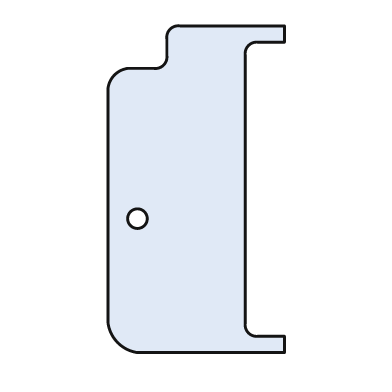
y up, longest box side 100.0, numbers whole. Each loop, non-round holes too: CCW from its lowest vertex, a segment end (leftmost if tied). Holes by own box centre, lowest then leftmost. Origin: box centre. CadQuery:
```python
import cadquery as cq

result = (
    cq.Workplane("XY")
    .moveTo(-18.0, -50.0)
    .lineTo(27.0, -50.0)
    .lineTo(27.0, -45.0)
    .lineTo(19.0, -45.0)
    .threePointArc((16.0, -44.0), (15.0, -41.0))
    .lineTo(15.0, 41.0)
    .threePointArc((16.0, 44.0), (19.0, 45.0))
    .lineTo(27.0, 45.0)
    .lineTo(27.0, 50.0)
    .lineTo(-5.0, 50.0)
    .threePointArc((-8.0, 49.0), (-9.0, 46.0))
    .lineTo(-9.0, 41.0)
    .threePointArc((-10.0, 38.0), (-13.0, 37.0))
    .lineTo(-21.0, 37.0)
    .threePointArc((-25.0, 35.0), (-27.0, 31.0))
    .lineTo(-27.0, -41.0)
    .threePointArc((-24.0, -47.0), (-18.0, -50.0))
    .close()
    .moveTo(-18.0, -9.0)
    .circle(3.0)
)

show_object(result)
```